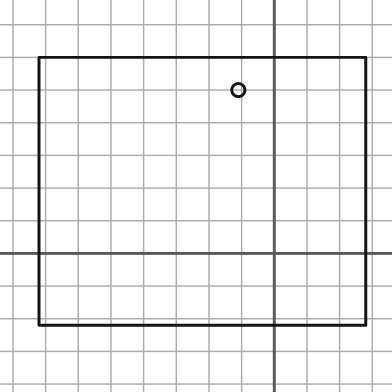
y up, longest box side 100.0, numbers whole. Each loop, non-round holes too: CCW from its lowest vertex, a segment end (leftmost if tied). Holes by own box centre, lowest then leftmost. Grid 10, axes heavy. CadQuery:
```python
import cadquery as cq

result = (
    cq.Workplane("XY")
    .moveTo(-72.0, -22.0)
    .lineTo(28.0, -22.0)
    .lineTo(28.0, 60.0)
    .lineTo(-72.0, 60.0)
    .close()
    .moveTo(-11.0, 50.0)
    .circle(2.0)
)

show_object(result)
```